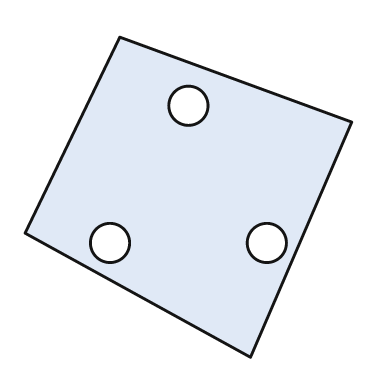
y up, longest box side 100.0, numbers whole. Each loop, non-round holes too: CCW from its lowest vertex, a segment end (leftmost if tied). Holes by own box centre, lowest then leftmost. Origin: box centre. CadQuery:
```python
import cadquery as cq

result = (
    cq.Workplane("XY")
    .moveTo(19.0, -49.0)
    .lineTo(50.0, 23.0)
    .lineTo(-21.0, 49.0)
    .lineTo(-50.0, -11.0)
    .close()
    .moveTo(-24.0, -14.0)
    .circle(6.0)
    .moveTo(24.0, -14.0)
    .circle(6.0)
    .moveTo(0.0, 28.0)
    .circle(6.0)
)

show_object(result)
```